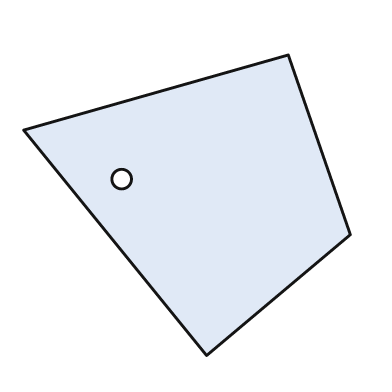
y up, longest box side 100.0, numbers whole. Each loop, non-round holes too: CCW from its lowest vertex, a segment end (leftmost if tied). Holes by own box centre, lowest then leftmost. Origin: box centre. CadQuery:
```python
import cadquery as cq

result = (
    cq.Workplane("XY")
    .moveTo(6.0, -46.0)
    .lineTo(50.0, -9.0)
    .lineTo(31.0, 46.0)
    .lineTo(-50.0, 23.0)
    .close()
    .moveTo(-20.0, 8.0)
    .circle(3.0)
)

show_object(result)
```